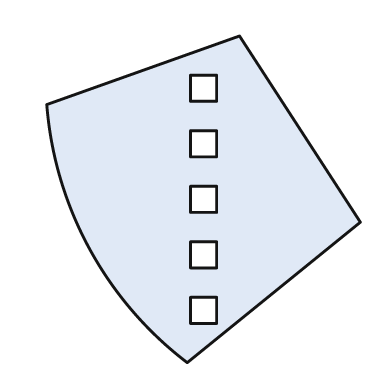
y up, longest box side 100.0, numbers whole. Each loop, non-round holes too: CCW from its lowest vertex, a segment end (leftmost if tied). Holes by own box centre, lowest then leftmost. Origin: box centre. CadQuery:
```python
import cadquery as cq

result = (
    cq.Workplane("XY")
    .moveTo(-5.0, -50.0)
    .lineTo(48.0, -7.0)
    .lineTo(11.0, 50.0)
    .lineTo(-48.0, 29.0)
    .threePointArc((-35.0, -15.0), (-5.0, -50.0))
    .close()
    .moveTo(-4.0, -38.0)
    .lineTo(4.0, -38.0)
    .lineTo(4.0, -30.0)
    .lineTo(-4.0, -30.0)
    .close()
    .moveTo(-4.0, -21.0)
    .lineTo(4.0, -21.0)
    .lineTo(4.0, -13.0)
    .lineTo(-4.0, -13.0)
    .close()
    .moveTo(-4.0, -4.0)
    .lineTo(4.0, -4.0)
    .lineTo(4.0, 4.0)
    .lineTo(-4.0, 4.0)
    .close()
    .moveTo(-4.0, 13.0)
    .lineTo(4.0, 13.0)
    .lineTo(4.0, 21.0)
    .lineTo(-4.0, 21.0)
    .close()
    .moveTo(-4.0, 30.0)
    .lineTo(4.0, 30.0)
    .lineTo(4.0, 38.0)
    .lineTo(-4.0, 38.0)
    .close()
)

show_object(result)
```